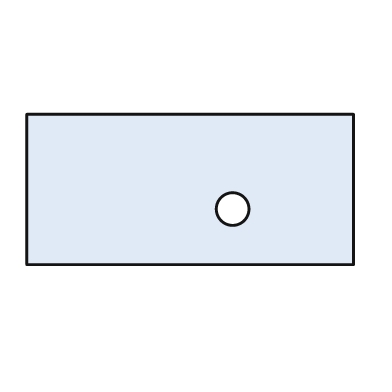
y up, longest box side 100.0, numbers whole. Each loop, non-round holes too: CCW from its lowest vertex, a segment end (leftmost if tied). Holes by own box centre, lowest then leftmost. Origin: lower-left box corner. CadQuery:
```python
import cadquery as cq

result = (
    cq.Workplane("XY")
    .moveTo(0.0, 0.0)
    .lineTo(100.0, 0.0)
    .lineTo(100.0, 46.0)
    .lineTo(0.0, 46.0)
    .close()
    .moveTo(63.0, 17.0)
    .circle(5.0)
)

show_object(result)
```